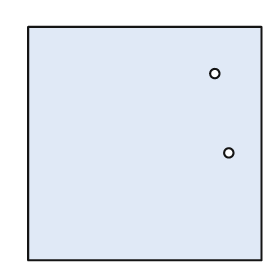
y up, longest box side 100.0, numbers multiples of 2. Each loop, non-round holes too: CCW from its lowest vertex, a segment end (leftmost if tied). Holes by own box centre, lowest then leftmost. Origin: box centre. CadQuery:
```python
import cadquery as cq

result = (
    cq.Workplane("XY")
    .moveTo(-50.0, -50.0)
    .lineTo(50.0, -50.0)
    .lineTo(50.0, 50.0)
    .lineTo(-50.0, 50.0)
    .close()
    .moveTo(36.0, -4.0)
    .circle(2.0)
    .moveTo(30.0, 30.0)
    .circle(2.0)
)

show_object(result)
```